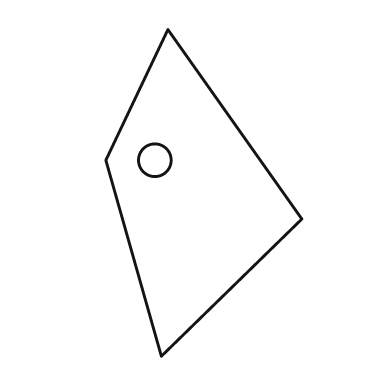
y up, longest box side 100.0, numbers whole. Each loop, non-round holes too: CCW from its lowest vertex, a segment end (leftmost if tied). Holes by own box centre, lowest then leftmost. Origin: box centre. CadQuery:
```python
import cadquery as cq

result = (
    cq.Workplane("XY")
    .moveTo(-13.0, -50.0)
    .lineTo(30.0, -8.0)
    .lineTo(-11.0, 50.0)
    .lineTo(-30.0, 10.0)
    .close()
    .moveTo(-15.0, 10.0)
    .circle(5.0)
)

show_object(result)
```